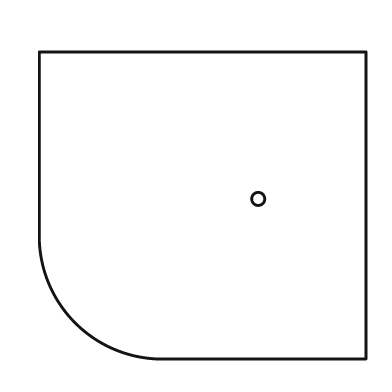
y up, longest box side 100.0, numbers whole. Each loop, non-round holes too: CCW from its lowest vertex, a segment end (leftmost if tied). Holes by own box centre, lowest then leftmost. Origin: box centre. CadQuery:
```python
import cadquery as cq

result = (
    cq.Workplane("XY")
    .moveTo(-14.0, -47.0)
    .lineTo(50.0, -47.0)
    .lineTo(50.0, 47.0)
    .lineTo(-50.0, 47.0)
    .lineTo(-50.0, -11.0)
    .threePointArc((-39.0, -36.0), (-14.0, -47.0))
    .close()
    .moveTo(17.0, 2.0)
    .circle(2.0)
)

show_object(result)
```